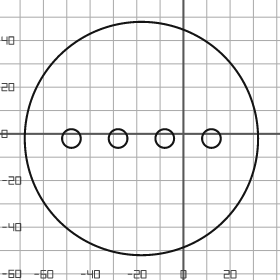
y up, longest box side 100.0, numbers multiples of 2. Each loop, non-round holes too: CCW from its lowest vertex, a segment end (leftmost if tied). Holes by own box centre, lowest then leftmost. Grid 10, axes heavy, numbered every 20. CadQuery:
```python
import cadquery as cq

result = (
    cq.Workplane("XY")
    .moveTo(-18.0, -2.0)
    .circle(50.0)
    .moveTo(-48.0, -2.0)
    .circle(4.0)
    .moveTo(-28.0, -2.0)
    .circle(4.0)
    .moveTo(-8.0, -2.0)
    .circle(4.0)
    .moveTo(12.0, -2.0)
    .circle(4.0)
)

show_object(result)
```